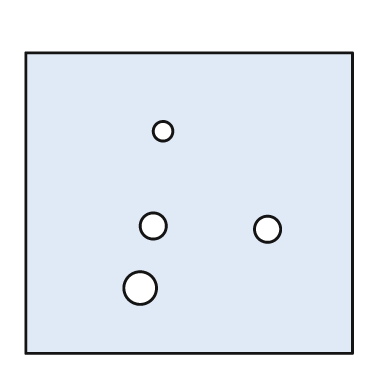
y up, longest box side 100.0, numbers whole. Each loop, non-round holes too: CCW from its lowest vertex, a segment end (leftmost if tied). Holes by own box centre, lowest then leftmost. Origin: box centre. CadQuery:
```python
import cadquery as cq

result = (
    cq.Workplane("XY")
    .moveTo(-50.0, -46.0)
    .lineTo(50.0, -46.0)
    .lineTo(50.0, 46.0)
    .lineTo(-50.0, 46.0)
    .close()
    .moveTo(-15.0, -26.0)
    .circle(5.0)
    .moveTo(24.0, -8.0)
    .circle(4.0)
    .moveTo(-11.0, -7.0)
    .circle(4.0)
    .moveTo(-8.0, 22.0)
    .circle(3.0)
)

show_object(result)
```